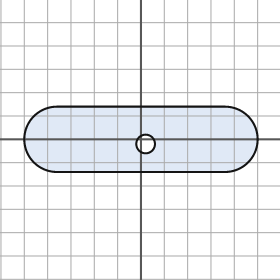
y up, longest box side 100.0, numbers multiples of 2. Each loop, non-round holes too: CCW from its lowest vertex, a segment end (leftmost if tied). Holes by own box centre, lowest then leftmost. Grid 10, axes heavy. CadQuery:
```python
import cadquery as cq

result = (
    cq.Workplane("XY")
    .moveTo(-36.0, -14.0)
    .lineTo(36.0, -14.0)
    .threePointArc((50.0, 0.0), (36.0, 14.0))
    .lineTo(-36.0, 14.0)
    .threePointArc((-50.0, 0.0), (-36.0, -14.0))
    .close()
    .moveTo(2.0, -2.0)
    .circle(4.0)
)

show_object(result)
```